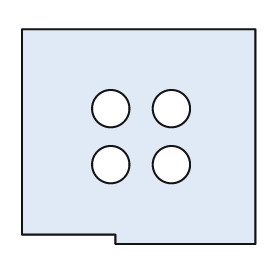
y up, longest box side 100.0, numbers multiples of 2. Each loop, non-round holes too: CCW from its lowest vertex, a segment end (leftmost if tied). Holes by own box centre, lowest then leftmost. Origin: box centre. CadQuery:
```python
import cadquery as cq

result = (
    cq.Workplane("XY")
    .moveTo(-10.0, -46.0)
    .lineTo(50.0, -46.0)
    .lineTo(50.0, 46.0)
    .lineTo(-50.0, 46.0)
    .lineTo(-50.0, -42.0)
    .lineTo(-10.0, -42.0)
    .close()
    .moveTo(-12.0, -12.0)
    .circle(8.0)
    .moveTo(14.0, -12.0)
    .circle(8.0)
    .moveTo(-12.0, 12.0)
    .circle(8.0)
    .moveTo(14.0, 12.0)
    .circle(8.0)
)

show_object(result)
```